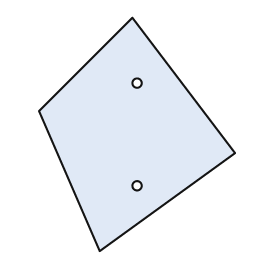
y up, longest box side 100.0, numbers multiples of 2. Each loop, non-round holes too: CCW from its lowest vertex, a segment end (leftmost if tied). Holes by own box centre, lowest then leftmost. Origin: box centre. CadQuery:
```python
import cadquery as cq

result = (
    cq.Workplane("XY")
    .moveTo(-16.0, -50.0)
    .lineTo(42.0, -8.0)
    .lineTo(-2.0, 50.0)
    .lineTo(-42.0, 10.0)
    .close()
    .moveTo(0.0, -22.0)
    .circle(2.0)
    .moveTo(0.0, 22.0)
    .circle(2.0)
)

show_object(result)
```